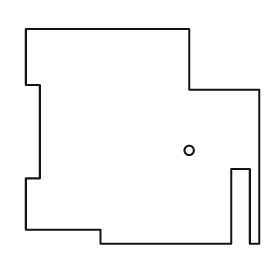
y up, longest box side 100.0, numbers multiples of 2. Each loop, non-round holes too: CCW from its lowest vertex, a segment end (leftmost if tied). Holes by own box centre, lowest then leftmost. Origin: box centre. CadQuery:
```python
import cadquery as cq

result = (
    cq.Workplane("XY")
    .moveTo(-18.0, -46.0)
    .lineTo(38.0, -46.0)
    .lineTo(38.0, -14.0)
    .lineTo(46.0, -14.0)
    .lineTo(46.0, -46.0)
    .lineTo(50.0, -46.0)
    .lineTo(50.0, 20.0)
    .lineTo(20.0, 20.0)
    .lineTo(20.0, 46.0)
    .lineTo(-50.0, 46.0)
    .lineTo(-50.0, 22.0)
    .lineTo(-44.0, 22.0)
    .lineTo(-44.0, -18.0)
    .lineTo(-50.0, -18.0)
    .lineTo(-50.0, -40.0)
    .lineTo(-18.0, -40.0)
    .close()
    .moveTo(20.0, -6.0)
    .circle(2.0)
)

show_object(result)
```